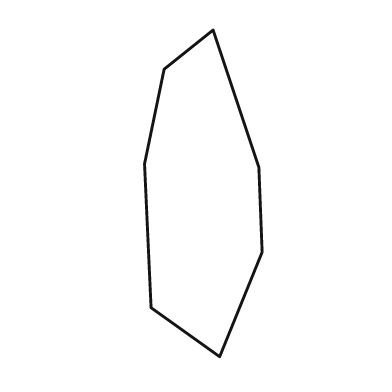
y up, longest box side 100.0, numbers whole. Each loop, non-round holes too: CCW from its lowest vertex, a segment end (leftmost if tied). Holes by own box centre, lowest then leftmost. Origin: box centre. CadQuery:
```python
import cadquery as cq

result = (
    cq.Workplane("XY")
    .moveTo(5.0, -50.0)
    .lineTo(18.0, -18.0)
    .lineTo(17.0, 8.0)
    .lineTo(3.0, 50.0)
    .lineTo(-12.0, 38.0)
    .lineTo(-18.0, 9.0)
    .lineTo(-16.0, -35.0)
    .close()
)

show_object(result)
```